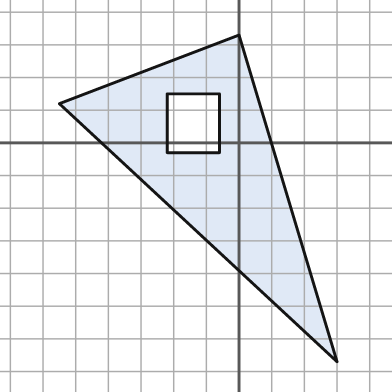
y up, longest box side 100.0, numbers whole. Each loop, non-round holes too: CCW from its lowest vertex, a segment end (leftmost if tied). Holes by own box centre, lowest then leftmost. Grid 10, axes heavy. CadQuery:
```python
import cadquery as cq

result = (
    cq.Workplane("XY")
    .moveTo(30.0, -67.0)
    .lineTo(0.0, 33.0)
    .lineTo(-55.0, 12.0)
    .close()
    .moveTo(-22.0, -3.0)
    .lineTo(-6.0, -3.0)
    .lineTo(-6.0, 15.0)
    .lineTo(-22.0, 15.0)
    .close()
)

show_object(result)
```